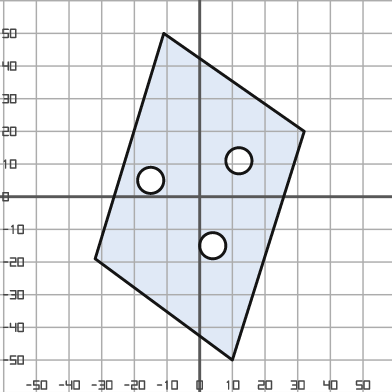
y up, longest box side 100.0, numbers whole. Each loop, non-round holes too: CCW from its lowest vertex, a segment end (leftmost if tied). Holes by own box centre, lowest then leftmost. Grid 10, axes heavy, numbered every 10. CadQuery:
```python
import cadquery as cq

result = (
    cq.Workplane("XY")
    .moveTo(10.0, -50.0)
    .lineTo(32.0, 20.0)
    .lineTo(-11.0, 50.0)
    .lineTo(-32.0, -19.0)
    .close()
    .moveTo(4.0, -15.0)
    .circle(4.0)
    .moveTo(-15.0, 5.0)
    .circle(4.0)
    .moveTo(12.0, 11.0)
    .circle(4.0)
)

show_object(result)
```